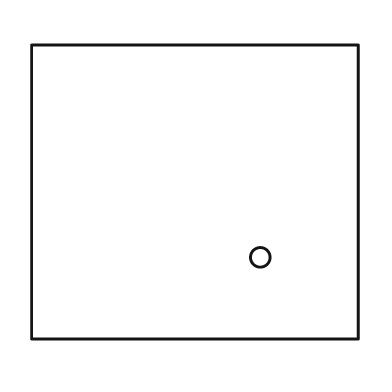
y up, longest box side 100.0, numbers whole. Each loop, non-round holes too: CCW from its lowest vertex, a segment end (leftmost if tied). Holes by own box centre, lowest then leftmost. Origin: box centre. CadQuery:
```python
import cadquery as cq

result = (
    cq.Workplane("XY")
    .moveTo(-50.0, -45.0)
    .lineTo(50.0, -45.0)
    .lineTo(50.0, 45.0)
    .lineTo(-50.0, 45.0)
    .close()
    .moveTo(20.0, -20.0)
    .circle(3.0)
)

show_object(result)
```